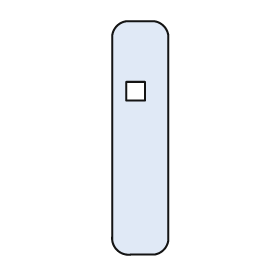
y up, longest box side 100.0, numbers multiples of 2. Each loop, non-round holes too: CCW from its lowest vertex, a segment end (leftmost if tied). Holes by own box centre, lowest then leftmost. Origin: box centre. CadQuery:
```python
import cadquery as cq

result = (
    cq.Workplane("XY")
    .moveTo(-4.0, -50.0)
    .lineTo(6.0, -50.0)
    .threePointArc((10.0, -48.0), (12.0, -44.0))
    .lineTo(12.0, 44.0)
    .threePointArc((10.0, 48.0), (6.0, 50.0))
    .lineTo(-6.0, 50.0)
    .threePointArc((-10.0, 48.0), (-12.0, 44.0))
    .lineTo(-12.0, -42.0)
    .threePointArc((-10.0, -48.0), (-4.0, -50.0))
    .close()
    .moveTo(-6.0, 16.0)
    .lineTo(2.0, 16.0)
    .lineTo(2.0, 24.0)
    .lineTo(-6.0, 24.0)
    .close()
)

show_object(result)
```